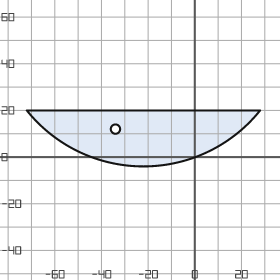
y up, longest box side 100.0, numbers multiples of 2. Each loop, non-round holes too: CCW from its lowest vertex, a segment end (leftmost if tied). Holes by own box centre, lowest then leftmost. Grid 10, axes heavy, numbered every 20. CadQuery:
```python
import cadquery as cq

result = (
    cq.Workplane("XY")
    .moveTo(-72.0, 20.0)
    .threePointArc((-22.0, -4.0), (28.0, 20.0))
    .close()
    .moveTo(-34.0, 12.0)
    .circle(2.0)
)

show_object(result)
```